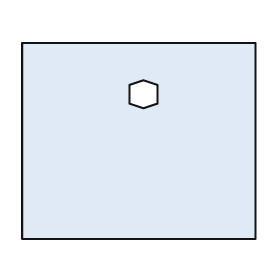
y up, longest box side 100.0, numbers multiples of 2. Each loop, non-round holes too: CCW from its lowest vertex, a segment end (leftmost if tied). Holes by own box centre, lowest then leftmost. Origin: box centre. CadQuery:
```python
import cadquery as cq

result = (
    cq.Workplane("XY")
    .moveTo(-50.0, -42.0)
    .lineTo(50.0, -42.0)
    .lineTo(50.0, 42.0)
    .lineTo(-50.0, 42.0)
    .close()
    .moveTo(2.0, 14.0)
    .lineTo(8.0, 16.0)
    .lineTo(8.0, 24.0)
    .lineTo(2.0, 26.0)
    .lineTo(-4.0, 24.0)
    .lineTo(-4.0, 16.0)
    .close()
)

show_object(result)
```